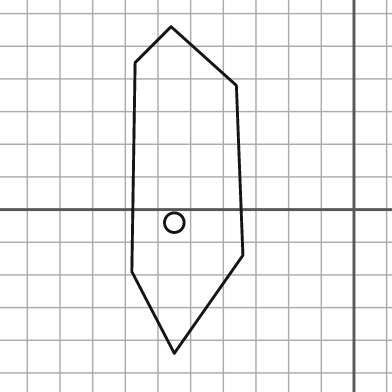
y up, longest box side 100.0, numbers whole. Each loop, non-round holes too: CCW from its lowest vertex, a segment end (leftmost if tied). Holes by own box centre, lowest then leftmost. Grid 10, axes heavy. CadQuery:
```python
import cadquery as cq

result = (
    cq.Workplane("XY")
    .moveTo(-55.0, -44.0)
    .lineTo(-34.0, -14.0)
    .lineTo(-36.0, 38.0)
    .lineTo(-56.0, 56.0)
    .lineTo(-67.0, 45.0)
    .lineTo(-68.0, -19.0)
    .close()
    .moveTo(-55.0, -4.0)
    .circle(3.0)
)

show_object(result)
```